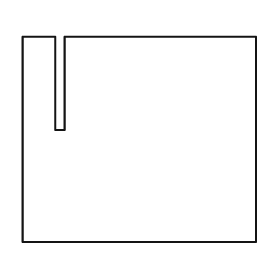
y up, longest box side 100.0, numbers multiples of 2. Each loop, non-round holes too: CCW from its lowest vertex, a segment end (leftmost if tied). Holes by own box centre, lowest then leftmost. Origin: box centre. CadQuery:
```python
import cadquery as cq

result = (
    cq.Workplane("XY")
    .moveTo(-50.0, -44.0)
    .lineTo(50.0, -44.0)
    .lineTo(50.0, 44.0)
    .lineTo(-32.0, 44.0)
    .lineTo(-32.0, 4.0)
    .lineTo(-36.0, 4.0)
    .lineTo(-36.0, 44.0)
    .lineTo(-50.0, 44.0)
    .close()
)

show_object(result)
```